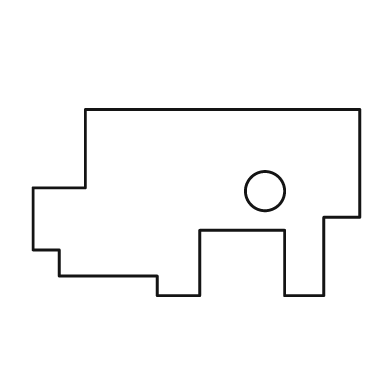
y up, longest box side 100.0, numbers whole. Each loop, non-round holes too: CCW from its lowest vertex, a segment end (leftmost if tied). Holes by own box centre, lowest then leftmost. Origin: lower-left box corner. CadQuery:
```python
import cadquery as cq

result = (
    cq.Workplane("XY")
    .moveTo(38.0, 0.0)
    .lineTo(51.0, 0.0)
    .lineTo(51.0, 20.0)
    .lineTo(77.0, 20.0)
    .lineTo(77.0, 0.0)
    .lineTo(89.0, 0.0)
    .lineTo(89.0, 24.0)
    .lineTo(100.0, 24.0)
    .lineTo(100.0, 57.0)
    .lineTo(16.0, 57.0)
    .lineTo(16.0, 33.0)
    .lineTo(0.0, 33.0)
    .lineTo(0.0, 14.0)
    .lineTo(8.0, 14.0)
    .lineTo(8.0, 6.0)
    .lineTo(38.0, 6.0)
    .close()
    .moveTo(71.0, 32.0)
    .circle(6.0)
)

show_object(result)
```